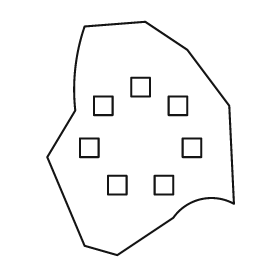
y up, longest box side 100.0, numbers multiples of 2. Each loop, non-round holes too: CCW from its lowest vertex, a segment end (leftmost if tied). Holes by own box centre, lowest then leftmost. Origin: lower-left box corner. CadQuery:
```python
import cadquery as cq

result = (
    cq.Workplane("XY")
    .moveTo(30.0, 0.0)
    .lineTo(54.0, 16.0)
    .threePointArc((66.0, 24.0), (80.0, 22.0))
    .lineTo(78.0, 64.0)
    .lineTo(60.0, 88.0)
    .lineTo(42.0, 100.0)
    .lineTo(16.0, 98.0)
    .threePointArc((12.0, 80.0), (12.0, 62.0))
    .lineTo(0.0, 42.0)
    .lineTo(16.0, 4.0)
    .close()
    .moveTo(26.0, 26.0)
    .lineTo(34.0, 26.0)
    .lineTo(34.0, 34.0)
    .lineTo(26.0, 34.0)
    .close()
    .moveTo(46.0, 26.0)
    .lineTo(54.0, 26.0)
    .lineTo(54.0, 34.0)
    .lineTo(46.0, 34.0)
    .close()
    .moveTo(14.0, 42.0)
    .lineTo(22.0, 42.0)
    .lineTo(22.0, 50.0)
    .lineTo(14.0, 50.0)
    .close()
    .moveTo(58.0, 42.0)
    .lineTo(66.0, 42.0)
    .lineTo(66.0, 50.0)
    .lineTo(58.0, 50.0)
    .close()
    .moveTo(20.0, 60.0)
    .lineTo(28.0, 60.0)
    .lineTo(28.0, 68.0)
    .lineTo(20.0, 68.0)
    .close()
    .moveTo(52.0, 60.0)
    .lineTo(60.0, 60.0)
    .lineTo(60.0, 68.0)
    .lineTo(52.0, 68.0)
    .close()
    .moveTo(36.0, 68.0)
    .lineTo(44.0, 68.0)
    .lineTo(44.0, 76.0)
    .lineTo(36.0, 76.0)
    .close()
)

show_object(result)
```